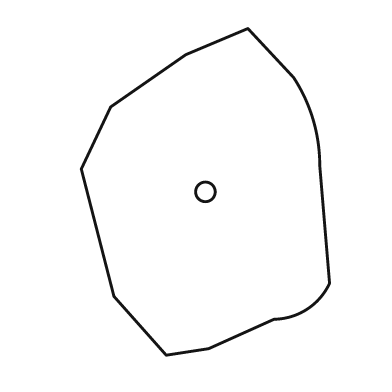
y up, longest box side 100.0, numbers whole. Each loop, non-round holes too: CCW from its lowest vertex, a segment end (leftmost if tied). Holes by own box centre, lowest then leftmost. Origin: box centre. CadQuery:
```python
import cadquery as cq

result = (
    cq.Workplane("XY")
    .moveTo(-12.0, -50.0)
    .lineTo(1.0, -48.0)
    .lineTo(21.0, -39.0)
    .threePointArc((31.0, -36.0), (38.0, -28.0))
    .lineTo(35.0, 8.0)
    .threePointArc((33.0, 22.0), (27.0, 35.0))
    .lineTo(13.0, 50.0)
    .lineTo(-6.0, 42.0)
    .lineTo(-29.0, 26.0)
    .lineTo(-38.0, 7.0)
    .lineTo(-28.0, -32.0)
    .close()
    .moveTo(0.0, 0.0)
    .circle(3.0)
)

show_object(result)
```